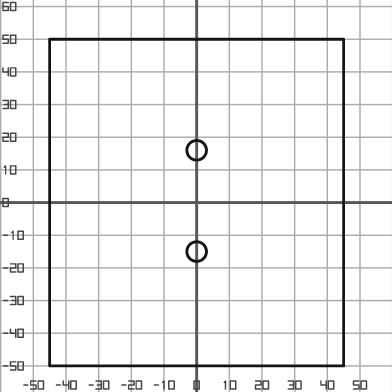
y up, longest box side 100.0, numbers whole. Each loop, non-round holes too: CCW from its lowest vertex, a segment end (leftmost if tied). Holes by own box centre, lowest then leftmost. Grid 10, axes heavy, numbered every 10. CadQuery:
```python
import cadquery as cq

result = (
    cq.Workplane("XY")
    .moveTo(-45.0, -50.0)
    .lineTo(45.0, -50.0)
    .lineTo(45.0, 50.0)
    .lineTo(-45.0, 50.0)
    .close()
    .moveTo(0.0, -15.0)
    .circle(3.0)
    .moveTo(0.0, 16.0)
    .circle(3.0)
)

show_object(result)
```